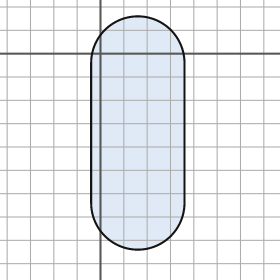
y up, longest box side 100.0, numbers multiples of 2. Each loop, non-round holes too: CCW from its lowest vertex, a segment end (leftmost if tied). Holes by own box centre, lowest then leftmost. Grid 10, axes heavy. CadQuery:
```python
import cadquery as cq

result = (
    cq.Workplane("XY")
    .moveTo(-4.0, -64.0)
    .threePointArc((16.0, -84.0), (36.0, -64.0))
    .lineTo(36.0, -4.0)
    .threePointArc((16.0, 16.0), (-4.0, -4.0))
    .close()
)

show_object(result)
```